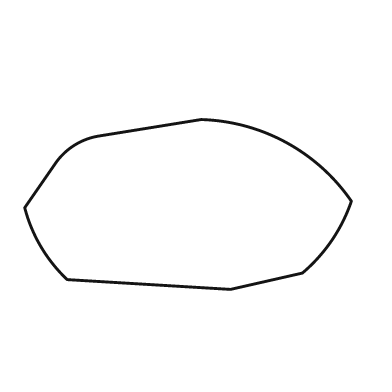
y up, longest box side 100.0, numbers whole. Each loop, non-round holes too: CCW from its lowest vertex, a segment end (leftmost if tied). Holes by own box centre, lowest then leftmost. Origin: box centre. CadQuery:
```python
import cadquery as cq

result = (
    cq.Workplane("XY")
    .moveTo(13.0, -26.0)
    .lineTo(35.0, -21.0)
    .threePointArc((44.0, -11.0), (50.0, 1.0))
    .threePointArc((30.0, 19.0), (4.0, 26.0))
    .lineTo(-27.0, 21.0)
    .threePointArc((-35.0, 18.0), (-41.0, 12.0))
    .lineTo(-50.0, -1.0)
    .threePointArc((-45.0, -13.0), (-37.0, -23.0))
    .close()
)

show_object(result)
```